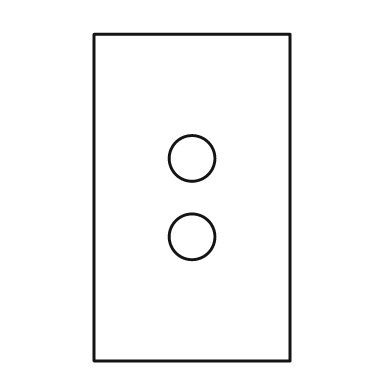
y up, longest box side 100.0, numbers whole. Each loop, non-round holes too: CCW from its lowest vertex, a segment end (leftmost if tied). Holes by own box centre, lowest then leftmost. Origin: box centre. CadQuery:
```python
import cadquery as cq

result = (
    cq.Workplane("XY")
    .moveTo(-30.0, -50.0)
    .lineTo(30.0, -50.0)
    .lineTo(30.0, 50.0)
    .lineTo(-30.0, 50.0)
    .close()
    .moveTo(0.0, -12.0)
    .circle(7.0)
    .moveTo(0.0, 12.0)
    .circle(7.0)
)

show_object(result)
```